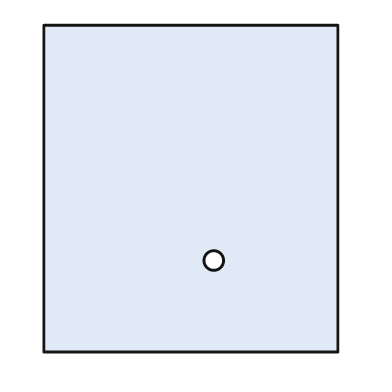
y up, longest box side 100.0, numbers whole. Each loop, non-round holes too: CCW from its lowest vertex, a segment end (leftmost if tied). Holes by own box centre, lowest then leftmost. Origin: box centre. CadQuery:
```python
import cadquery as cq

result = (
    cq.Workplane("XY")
    .moveTo(-45.0, -50.0)
    .lineTo(45.0, -50.0)
    .lineTo(45.0, 50.0)
    .lineTo(-45.0, 50.0)
    .close()
    .moveTo(7.0, -22.0)
    .circle(3.0)
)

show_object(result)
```